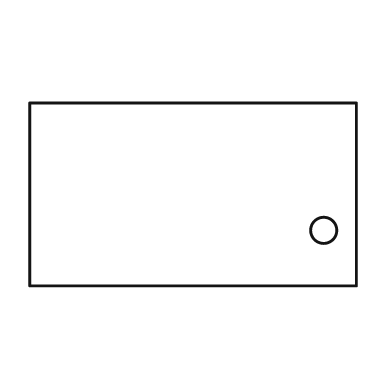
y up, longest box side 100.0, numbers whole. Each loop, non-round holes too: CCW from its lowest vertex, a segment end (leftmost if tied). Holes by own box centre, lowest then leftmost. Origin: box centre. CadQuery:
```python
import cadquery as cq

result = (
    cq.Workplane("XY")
    .moveTo(-50.0, -28.0)
    .lineTo(50.0, -28.0)
    .lineTo(50.0, 28.0)
    .lineTo(-50.0, 28.0)
    .close()
    .moveTo(40.0, -11.0)
    .circle(4.0)
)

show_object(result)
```